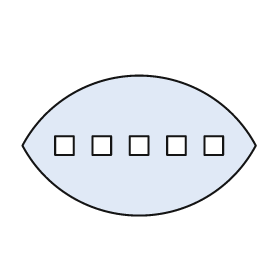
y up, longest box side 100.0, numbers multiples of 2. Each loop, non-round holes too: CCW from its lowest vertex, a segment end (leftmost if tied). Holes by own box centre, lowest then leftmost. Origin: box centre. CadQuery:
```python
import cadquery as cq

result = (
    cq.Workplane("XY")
    .moveTo(-50.0, 0.0)
    .threePointArc((0.0, -30.0), (50.0, 0.0))
    .threePointArc((0.0, 30.0), (-50.0, 0.0))
    .close()
    .moveTo(-36.0, -4.0)
    .lineTo(-28.0, -4.0)
    .lineTo(-28.0, 4.0)
    .lineTo(-36.0, 4.0)
    .close()
    .moveTo(-20.0, -4.0)
    .lineTo(-12.0, -4.0)
    .lineTo(-12.0, 4.0)
    .lineTo(-20.0, 4.0)
    .close()
    .moveTo(-4.0, -4.0)
    .lineTo(4.0, -4.0)
    .lineTo(4.0, 4.0)
    .lineTo(-4.0, 4.0)
    .close()
    .moveTo(12.0, -4.0)
    .lineTo(20.0, -4.0)
    .lineTo(20.0, 4.0)
    .lineTo(12.0, 4.0)
    .close()
    .moveTo(28.0, -4.0)
    .lineTo(36.0, -4.0)
    .lineTo(36.0, 4.0)
    .lineTo(28.0, 4.0)
    .close()
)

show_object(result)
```